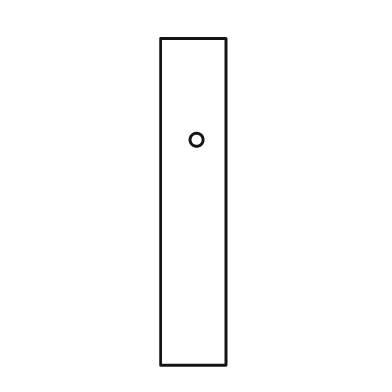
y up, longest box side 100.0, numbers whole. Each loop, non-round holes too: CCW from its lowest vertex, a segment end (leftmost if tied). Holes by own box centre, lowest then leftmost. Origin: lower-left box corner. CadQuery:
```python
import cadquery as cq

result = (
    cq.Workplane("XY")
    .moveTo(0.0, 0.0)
    .lineTo(20.0, 0.0)
    .lineTo(20.0, 100.0)
    .lineTo(0.0, 100.0)
    .close()
    .moveTo(11.0, 69.0)
    .circle(2.0)
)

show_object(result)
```